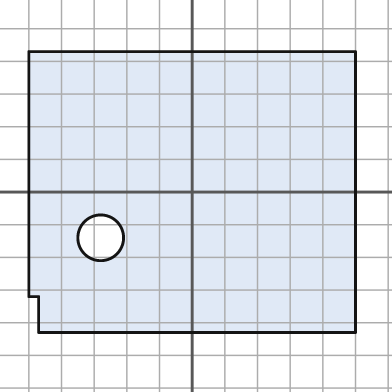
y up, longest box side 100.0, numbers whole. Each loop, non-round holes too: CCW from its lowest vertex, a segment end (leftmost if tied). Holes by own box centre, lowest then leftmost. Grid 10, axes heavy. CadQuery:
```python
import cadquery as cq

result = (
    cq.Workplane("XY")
    .moveTo(-47.0, -43.0)
    .lineTo(50.0, -43.0)
    .lineTo(50.0, 43.0)
    .lineTo(-50.0, 43.0)
    .lineTo(-50.0, -32.0)
    .lineTo(-47.0, -32.0)
    .close()
    .moveTo(-28.0, -14.0)
    .circle(7.0)
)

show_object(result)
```